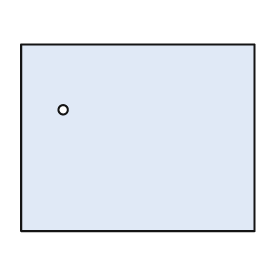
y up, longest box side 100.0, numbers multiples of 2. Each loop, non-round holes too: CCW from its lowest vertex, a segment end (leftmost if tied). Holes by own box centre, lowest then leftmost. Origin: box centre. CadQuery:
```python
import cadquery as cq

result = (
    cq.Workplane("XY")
    .moveTo(-50.0, -40.0)
    .lineTo(50.0, -40.0)
    .lineTo(50.0, 40.0)
    .lineTo(-50.0, 40.0)
    .close()
    .moveTo(-32.0, 12.0)
    .circle(2.0)
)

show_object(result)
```